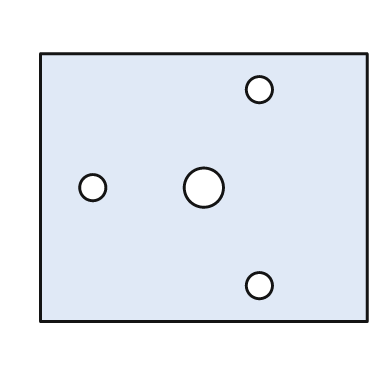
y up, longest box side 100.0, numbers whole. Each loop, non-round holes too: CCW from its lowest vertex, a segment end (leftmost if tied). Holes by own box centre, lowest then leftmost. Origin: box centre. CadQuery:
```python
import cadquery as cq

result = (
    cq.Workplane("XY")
    .moveTo(-50.0, -41.0)
    .lineTo(50.0, -41.0)
    .lineTo(50.0, 41.0)
    .lineTo(-50.0, 41.0)
    .close()
    .moveTo(17.0, -30.0)
    .circle(4.0)
    .moveTo(-34.0, 0.0)
    .circle(4.0)
    .moveTo(0.0, 0.0)
    .circle(6.0)
    .moveTo(17.0, 30.0)
    .circle(4.0)
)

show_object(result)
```